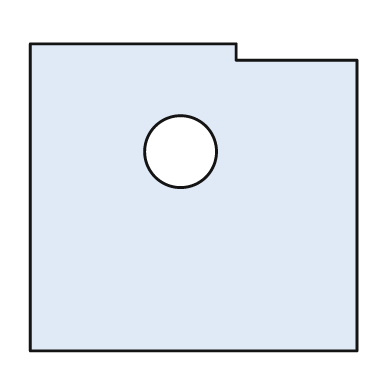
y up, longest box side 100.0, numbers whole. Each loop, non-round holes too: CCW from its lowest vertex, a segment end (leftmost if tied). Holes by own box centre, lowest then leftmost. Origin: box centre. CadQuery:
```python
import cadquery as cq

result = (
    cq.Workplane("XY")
    .moveTo(-50.0, -47.0)
    .lineTo(50.0, -47.0)
    .lineTo(50.0, 42.0)
    .lineTo(13.0, 42.0)
    .lineTo(13.0, 47.0)
    .lineTo(-50.0, 47.0)
    .close()
    .moveTo(-4.0, 14.0)
    .circle(11.0)
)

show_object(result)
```